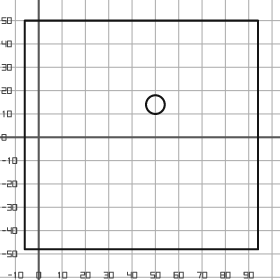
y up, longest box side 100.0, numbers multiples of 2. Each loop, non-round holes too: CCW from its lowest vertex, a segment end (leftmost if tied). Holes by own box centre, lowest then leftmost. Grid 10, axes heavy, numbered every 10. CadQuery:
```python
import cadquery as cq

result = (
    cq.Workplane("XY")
    .moveTo(-6.0, -48.0)
    .lineTo(94.0, -48.0)
    .lineTo(94.0, 50.0)
    .lineTo(-6.0, 50.0)
    .close()
    .moveTo(50.0, 14.0)
    .circle(4.0)
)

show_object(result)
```